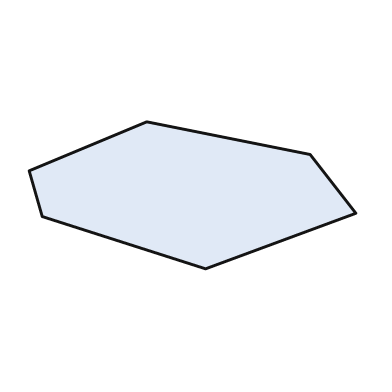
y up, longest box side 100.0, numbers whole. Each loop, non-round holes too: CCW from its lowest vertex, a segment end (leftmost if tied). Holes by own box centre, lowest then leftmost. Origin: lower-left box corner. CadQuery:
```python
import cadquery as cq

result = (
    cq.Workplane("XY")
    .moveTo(54.0, 0.0)
    .lineTo(100.0, 17.0)
    .lineTo(86.0, 35.0)
    .lineTo(36.0, 45.0)
    .lineTo(0.0, 30.0)
    .lineTo(4.0, 16.0)
    .close()
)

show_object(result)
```